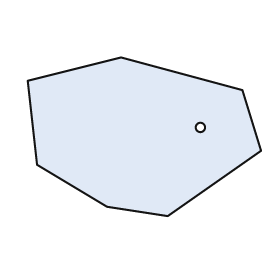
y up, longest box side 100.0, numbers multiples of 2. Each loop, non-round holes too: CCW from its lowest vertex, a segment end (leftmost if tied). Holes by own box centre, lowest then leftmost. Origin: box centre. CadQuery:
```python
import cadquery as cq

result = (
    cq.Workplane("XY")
    .moveTo(10.0, -34.0)
    .lineTo(50.0, -6.0)
    .lineTo(42.0, 20.0)
    .lineTo(-10.0, 34.0)
    .lineTo(-50.0, 24.0)
    .lineTo(-46.0, -12.0)
    .lineTo(-16.0, -30.0)
    .close()
    .moveTo(24.0, 4.0)
    .circle(2.0)
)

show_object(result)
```